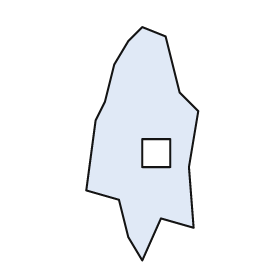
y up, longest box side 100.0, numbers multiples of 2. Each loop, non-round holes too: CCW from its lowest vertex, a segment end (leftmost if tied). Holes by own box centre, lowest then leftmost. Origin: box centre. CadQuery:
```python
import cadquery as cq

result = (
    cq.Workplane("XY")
    .moveTo(0.0, -50.0)
    .lineTo(8.0, -32.0)
    .lineTo(22.0, -36.0)
    .lineTo(20.0, -10.0)
    .lineTo(24.0, 14.0)
    .lineTo(16.0, 22.0)
    .lineTo(10.0, 46.0)
    .lineTo(0.0, 50.0)
    .lineTo(-6.0, 44.0)
    .lineTo(-12.0, 34.0)
    .lineTo(-16.0, 18.0)
    .lineTo(-20.0, 10.0)
    .lineTo(-24.0, -20.0)
    .lineTo(-10.0, -24.0)
    .lineTo(-6.0, -40.0)
    .close()
    .moveTo(0.0, -10.0)
    .lineTo(12.0, -10.0)
    .lineTo(12.0, 2.0)
    .lineTo(0.0, 2.0)
    .close()
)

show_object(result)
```